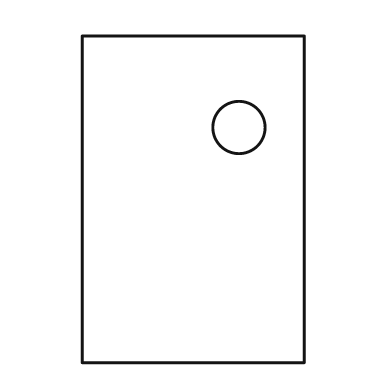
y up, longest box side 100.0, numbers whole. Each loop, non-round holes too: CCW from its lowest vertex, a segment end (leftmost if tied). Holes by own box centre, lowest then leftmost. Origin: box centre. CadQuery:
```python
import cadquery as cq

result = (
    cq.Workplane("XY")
    .moveTo(-34.0, -50.0)
    .lineTo(34.0, -50.0)
    .lineTo(34.0, 50.0)
    .lineTo(-34.0, 50.0)
    .close()
    .moveTo(14.0, 22.0)
    .circle(8.0)
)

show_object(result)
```